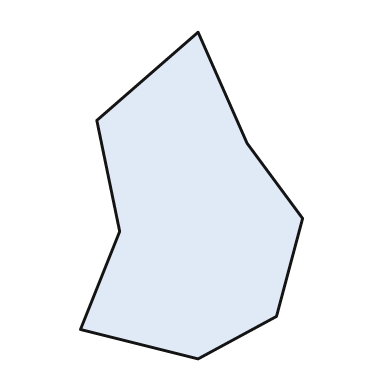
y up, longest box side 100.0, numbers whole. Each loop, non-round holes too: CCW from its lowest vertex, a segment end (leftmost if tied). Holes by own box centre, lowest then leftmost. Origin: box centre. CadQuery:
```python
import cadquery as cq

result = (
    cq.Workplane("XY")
    .moveTo(2.0, -50.0)
    .lineTo(26.0, -37.0)
    .lineTo(34.0, -7.0)
    .lineTo(17.0, 16.0)
    .lineTo(2.0, 50.0)
    .lineTo(-29.0, 23.0)
    .lineTo(-22.0, -11.0)
    .lineTo(-34.0, -41.0)
    .close()
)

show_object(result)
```